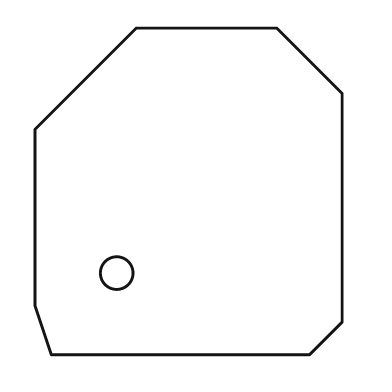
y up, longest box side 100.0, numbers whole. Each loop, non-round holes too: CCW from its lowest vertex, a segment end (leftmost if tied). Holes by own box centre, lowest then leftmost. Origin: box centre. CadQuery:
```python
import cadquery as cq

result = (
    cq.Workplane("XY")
    .moveTo(-42.0, -50.0)
    .lineTo(37.0, -50.0)
    .lineTo(47.0, -40.0)
    .lineTo(47.0, 30.0)
    .lineTo(27.0, 50.0)
    .lineTo(-16.0, 50.0)
    .lineTo(-47.0, 19.0)
    .lineTo(-47.0, -35.0)
    .close()
    .moveTo(-22.0, -25.0)
    .circle(5.0)
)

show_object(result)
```